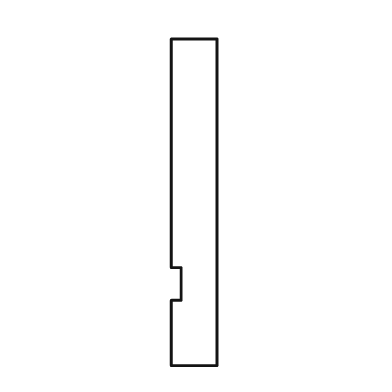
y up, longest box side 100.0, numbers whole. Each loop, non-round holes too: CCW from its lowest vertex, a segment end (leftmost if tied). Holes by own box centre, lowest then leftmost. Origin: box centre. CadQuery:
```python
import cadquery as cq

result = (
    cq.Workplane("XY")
    .moveTo(-7.0, -50.0)
    .lineTo(7.0, -50.0)
    .lineTo(7.0, 50.0)
    .lineTo(-7.0, 50.0)
    .lineTo(-7.0, -20.0)
    .lineTo(-4.0, -20.0)
    .lineTo(-4.0, -30.0)
    .lineTo(-7.0, -30.0)
    .close()
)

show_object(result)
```